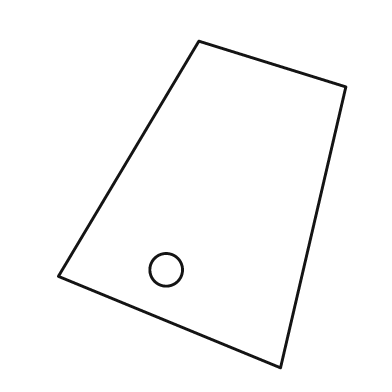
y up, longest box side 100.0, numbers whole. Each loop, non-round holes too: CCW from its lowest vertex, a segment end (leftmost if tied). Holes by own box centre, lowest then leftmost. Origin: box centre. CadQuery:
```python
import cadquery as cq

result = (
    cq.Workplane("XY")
    .moveTo(24.0, -50.0)
    .lineTo(44.0, 36.0)
    .lineTo(-1.0, 50.0)
    .lineTo(-44.0, -22.0)
    .close()
    .moveTo(-11.0, -20.0)
    .circle(5.0)
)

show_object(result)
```